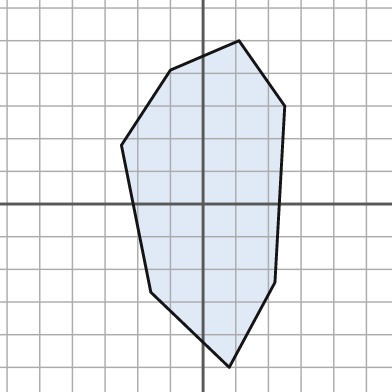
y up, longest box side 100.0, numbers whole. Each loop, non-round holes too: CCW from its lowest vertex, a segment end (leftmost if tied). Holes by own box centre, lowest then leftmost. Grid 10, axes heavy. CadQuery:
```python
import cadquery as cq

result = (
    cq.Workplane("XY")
    .moveTo(8.0, -50.0)
    .lineTo(22.0, -24.0)
    .lineTo(25.0, 30.0)
    .lineTo(11.0, 50.0)
    .lineTo(-10.0, 41.0)
    .lineTo(-25.0, 18.0)
    .lineTo(-16.0, -27.0)
    .close()
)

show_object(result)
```